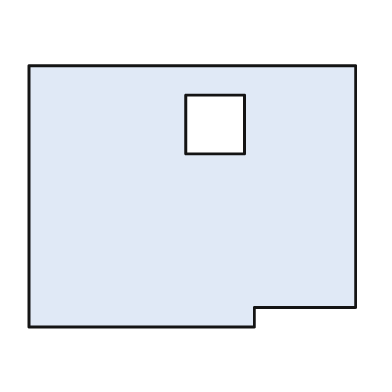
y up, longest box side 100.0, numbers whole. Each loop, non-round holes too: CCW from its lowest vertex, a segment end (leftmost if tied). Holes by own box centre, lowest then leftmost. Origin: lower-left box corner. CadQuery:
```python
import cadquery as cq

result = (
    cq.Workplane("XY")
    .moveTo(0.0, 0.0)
    .lineTo(69.0, 0.0)
    .lineTo(69.0, 6.0)
    .lineTo(100.0, 6.0)
    .lineTo(100.0, 80.0)
    .lineTo(0.0, 80.0)
    .close()
    .moveTo(48.0, 53.0)
    .lineTo(66.0, 53.0)
    .lineTo(66.0, 71.0)
    .lineTo(48.0, 71.0)
    .close()
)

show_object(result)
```